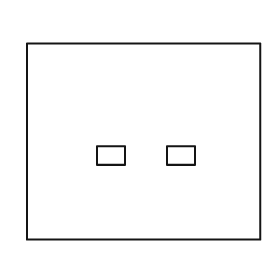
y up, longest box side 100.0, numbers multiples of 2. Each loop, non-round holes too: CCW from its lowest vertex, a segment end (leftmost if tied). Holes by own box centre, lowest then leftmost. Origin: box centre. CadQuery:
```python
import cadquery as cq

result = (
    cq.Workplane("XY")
    .moveTo(-50.0, -42.0)
    .lineTo(50.0, -42.0)
    .lineTo(50.0, 42.0)
    .lineTo(-50.0, 42.0)
    .close()
    .moveTo(-20.0, -10.0)
    .lineTo(-8.0, -10.0)
    .lineTo(-8.0, -2.0)
    .lineTo(-20.0, -2.0)
    .close()
    .moveTo(10.0, -10.0)
    .lineTo(22.0, -10.0)
    .lineTo(22.0, -2.0)
    .lineTo(10.0, -2.0)
    .close()
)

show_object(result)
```